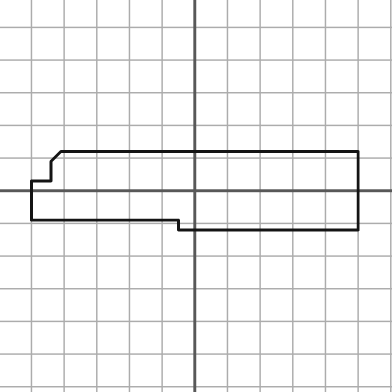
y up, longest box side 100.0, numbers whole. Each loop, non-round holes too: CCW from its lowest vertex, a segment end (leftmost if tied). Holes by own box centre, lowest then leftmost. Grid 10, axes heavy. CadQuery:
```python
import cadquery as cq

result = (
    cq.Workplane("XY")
    .moveTo(-5.0, -12.0)
    .lineTo(50.0, -12.0)
    .lineTo(50.0, 12.0)
    .lineTo(-41.0, 12.0)
    .lineTo(-44.0, 9.0)
    .lineTo(-44.0, 3.0)
    .lineTo(-50.0, 3.0)
    .lineTo(-50.0, -9.0)
    .lineTo(-5.0, -9.0)
    .close()
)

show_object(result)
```